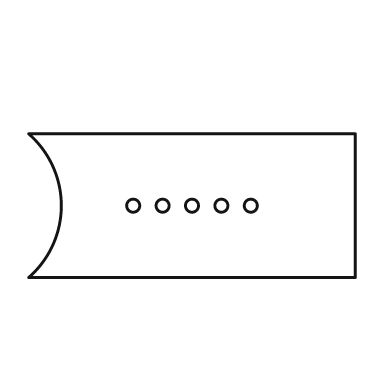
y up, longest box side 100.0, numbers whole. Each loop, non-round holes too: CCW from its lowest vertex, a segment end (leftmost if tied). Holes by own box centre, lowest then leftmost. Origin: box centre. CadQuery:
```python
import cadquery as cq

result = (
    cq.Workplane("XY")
    .moveTo(-50.0, -22.0)
    .lineTo(50.0, -22.0)
    .lineTo(50.0, 22.0)
    .lineTo(-50.0, 22.0)
    .threePointArc((-40.0, 0.0), (-50.0, -22.0))
    .close()
    .moveTo(-18.0, 0.0)
    .circle(2.0)
    .moveTo(-9.0, 0.0)
    .circle(2.0)
    .moveTo(0.0, 0.0)
    .circle(2.0)
    .moveTo(9.0, 0.0)
    .circle(2.0)
    .moveTo(18.0, 0.0)
    .circle(2.0)
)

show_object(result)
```